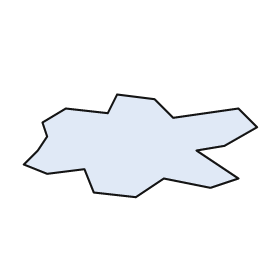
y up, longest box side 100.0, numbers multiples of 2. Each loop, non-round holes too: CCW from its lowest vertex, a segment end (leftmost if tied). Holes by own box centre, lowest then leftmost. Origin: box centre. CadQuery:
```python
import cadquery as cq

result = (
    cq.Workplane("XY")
    .moveTo(-2.0, -22.0)
    .lineTo(10.0, -14.0)
    .lineTo(30.0, -18.0)
    .lineTo(42.0, -14.0)
    .lineTo(24.0, -2.0)
    .lineTo(36.0, 0.0)
    .lineTo(50.0, 8.0)
    .lineTo(42.0, 16.0)
    .lineTo(14.0, 12.0)
    .lineTo(6.0, 20.0)
    .lineTo(-10.0, 22.0)
    .lineTo(-14.0, 14.0)
    .lineTo(-32.0, 16.0)
    .lineTo(-42.0, 10.0)
    .lineTo(-40.0, 4.0)
    .lineTo(-44.0, -2.0)
    .lineTo(-50.0, -8.0)
    .lineTo(-40.0, -12.0)
    .lineTo(-24.0, -10.0)
    .lineTo(-20.0, -20.0)
    .close()
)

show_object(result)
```